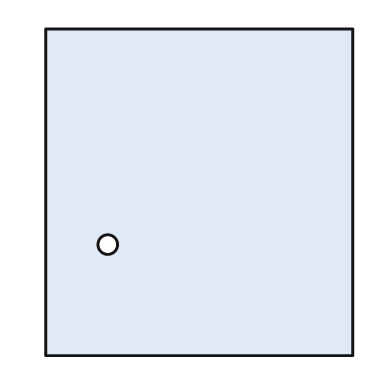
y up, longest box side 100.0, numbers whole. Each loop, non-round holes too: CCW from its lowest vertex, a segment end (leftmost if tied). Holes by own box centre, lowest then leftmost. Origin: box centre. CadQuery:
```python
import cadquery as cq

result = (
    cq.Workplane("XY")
    .moveTo(-47.0, -50.0)
    .lineTo(47.0, -50.0)
    .lineTo(47.0, 50.0)
    .lineTo(-47.0, 50.0)
    .close()
    .moveTo(-28.0, -16.0)
    .circle(3.0)
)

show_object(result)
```